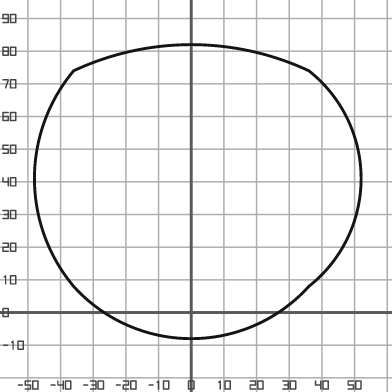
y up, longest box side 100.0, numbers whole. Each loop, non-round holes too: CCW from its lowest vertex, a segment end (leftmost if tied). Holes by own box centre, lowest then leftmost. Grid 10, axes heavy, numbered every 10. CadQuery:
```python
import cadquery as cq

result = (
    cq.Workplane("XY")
    .moveTo(-36.0, 8.0)
    .threePointArc((0.0, -8.0), (36.0, 8.0))
    .threePointArc((52.0, 41.0), (36.0, 74.0))
    .threePointArc((0.0, 82.0), (-36.0, 74.0))
    .threePointArc((-48.0, 41.0), (-36.0, 8.0))
    .close()
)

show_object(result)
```